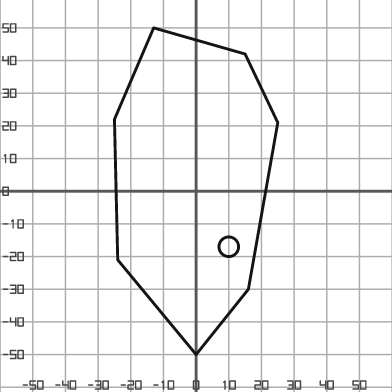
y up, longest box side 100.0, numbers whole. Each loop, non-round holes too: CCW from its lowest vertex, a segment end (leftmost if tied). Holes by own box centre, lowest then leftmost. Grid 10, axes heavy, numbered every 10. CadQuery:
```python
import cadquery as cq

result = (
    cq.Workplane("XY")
    .moveTo(0.0, -50.0)
    .lineTo(16.0, -30.0)
    .lineTo(25.0, 21.0)
    .lineTo(15.0, 42.0)
    .lineTo(-13.0, 50.0)
    .lineTo(-25.0, 22.0)
    .lineTo(-24.0, -21.0)
    .close()
    .moveTo(10.0, -17.0)
    .circle(3.0)
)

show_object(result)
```